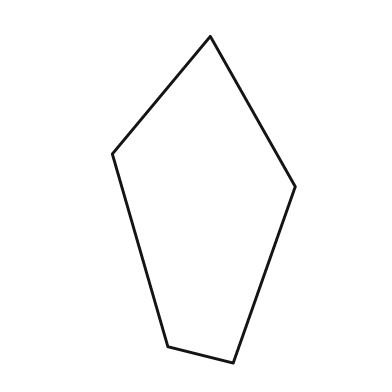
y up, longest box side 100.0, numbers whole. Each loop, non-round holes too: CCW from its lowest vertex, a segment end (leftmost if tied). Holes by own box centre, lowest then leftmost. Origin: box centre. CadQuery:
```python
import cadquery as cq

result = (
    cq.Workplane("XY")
    .moveTo(9.0, -50.0)
    .lineTo(28.0, 4.0)
    .lineTo(2.0, 50.0)
    .lineTo(-28.0, 14.0)
    .lineTo(-11.0, -45.0)
    .close()
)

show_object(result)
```